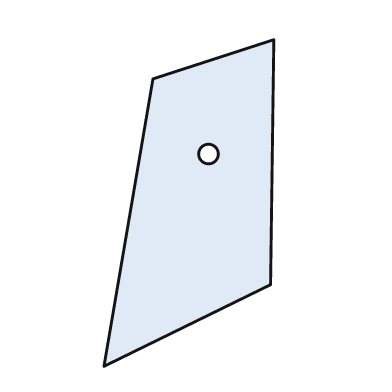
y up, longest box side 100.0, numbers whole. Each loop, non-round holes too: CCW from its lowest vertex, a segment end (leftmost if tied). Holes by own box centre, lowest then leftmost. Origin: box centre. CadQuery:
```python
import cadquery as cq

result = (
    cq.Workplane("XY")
    .moveTo(-26.0, -50.0)
    .lineTo(25.0, -25.0)
    .lineTo(26.0, 50.0)
    .lineTo(-11.0, 38.0)
    .close()
    .moveTo(6.0, 15.0)
    .circle(3.0)
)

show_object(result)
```